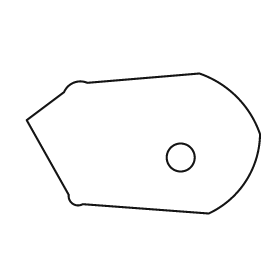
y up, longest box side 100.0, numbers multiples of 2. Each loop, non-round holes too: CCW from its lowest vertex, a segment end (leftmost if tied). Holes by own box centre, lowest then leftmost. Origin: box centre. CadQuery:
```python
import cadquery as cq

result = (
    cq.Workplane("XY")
    .moveTo(28.0, -30.0)
    .threePointArc((44.0, -16.0), (50.0, 4.0))
    .threePointArc((40.0, 20.0), (24.0, 30.0))
    .lineTo(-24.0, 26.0)
    .threePointArc((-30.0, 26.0), (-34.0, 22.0))
    .lineTo(-50.0, 10.0)
    .lineTo(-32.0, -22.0)
    .threePointArc((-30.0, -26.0), (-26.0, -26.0))
    .close()
    .moveTo(16.0, -6.0)
    .circle(6.0)
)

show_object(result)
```